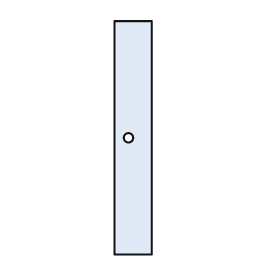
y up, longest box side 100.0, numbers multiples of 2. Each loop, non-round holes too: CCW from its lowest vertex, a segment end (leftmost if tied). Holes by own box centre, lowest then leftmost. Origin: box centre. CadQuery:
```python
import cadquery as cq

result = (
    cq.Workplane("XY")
    .moveTo(-8.0, -50.0)
    .lineTo(8.0, -50.0)
    .lineTo(8.0, 50.0)
    .lineTo(-8.0, 50.0)
    .close()
    .moveTo(-2.0, 0.0)
    .circle(2.0)
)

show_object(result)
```